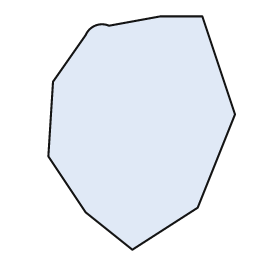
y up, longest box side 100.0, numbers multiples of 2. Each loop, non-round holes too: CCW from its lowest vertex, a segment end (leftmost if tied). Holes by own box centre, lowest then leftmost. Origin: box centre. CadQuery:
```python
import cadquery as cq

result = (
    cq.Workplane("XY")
    .moveTo(-4.0, -50.0)
    .lineTo(24.0, -32.0)
    .lineTo(40.0, 8.0)
    .lineTo(26.0, 50.0)
    .lineTo(8.0, 50.0)
    .lineTo(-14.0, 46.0)
    .threePointArc((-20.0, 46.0), (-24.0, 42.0))
    .lineTo(-38.0, 22.0)
    .lineTo(-40.0, -10.0)
    .lineTo(-24.0, -34.0)
    .close()
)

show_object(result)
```